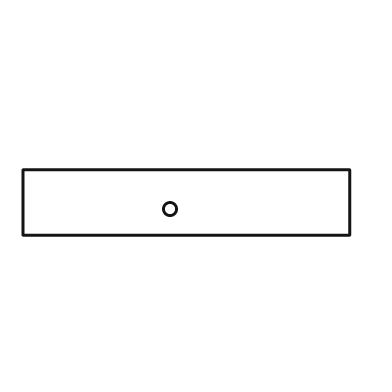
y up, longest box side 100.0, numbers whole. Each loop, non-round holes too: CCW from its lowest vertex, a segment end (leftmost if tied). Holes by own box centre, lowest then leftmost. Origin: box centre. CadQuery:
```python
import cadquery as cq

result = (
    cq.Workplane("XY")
    .moveTo(-50.0, -10.0)
    .lineTo(50.0, -10.0)
    .lineTo(50.0, 10.0)
    .lineTo(-50.0, 10.0)
    .close()
    .moveTo(-5.0, -2.0)
    .circle(2.0)
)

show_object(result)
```